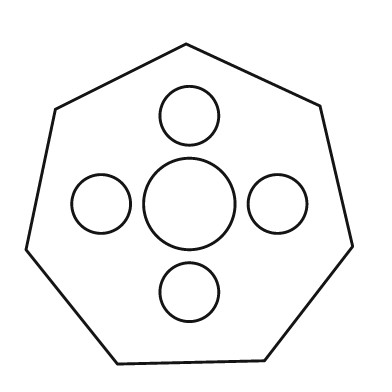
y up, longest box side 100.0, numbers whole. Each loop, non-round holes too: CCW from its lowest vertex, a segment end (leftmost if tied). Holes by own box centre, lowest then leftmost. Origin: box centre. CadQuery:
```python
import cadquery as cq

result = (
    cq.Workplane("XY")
    .moveTo(-22.0, -49.0)
    .lineTo(23.0, -48.0)
    .lineTo(50.0, -13.0)
    .lineTo(40.0, 30.0)
    .lineTo(-1.0, 49.0)
    .lineTo(-41.0, 29.0)
    .lineTo(-50.0, -14.0)
    .close()
    .moveTo(0.0, -27.0)
    .circle(9.0)
    .moveTo(-27.0, 0.0)
    .circle(9.0)
    .moveTo(0.0, 0.0)
    .circle(14.0)
    .moveTo(27.0, 0.0)
    .circle(9.0)
    .moveTo(0.0, 27.0)
    .circle(9.0)
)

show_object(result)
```